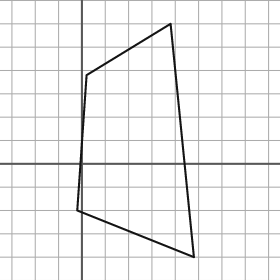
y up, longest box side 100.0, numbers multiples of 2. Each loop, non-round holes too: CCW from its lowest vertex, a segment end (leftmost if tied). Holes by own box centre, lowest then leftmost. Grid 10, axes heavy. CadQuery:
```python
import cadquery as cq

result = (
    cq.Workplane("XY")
    .moveTo(48.0, -40.0)
    .lineTo(38.0, 60.0)
    .lineTo(2.0, 38.0)
    .lineTo(-2.0, -20.0)
    .close()
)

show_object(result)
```